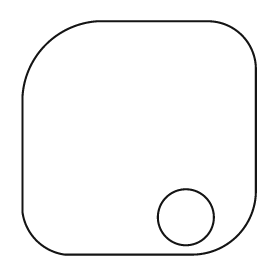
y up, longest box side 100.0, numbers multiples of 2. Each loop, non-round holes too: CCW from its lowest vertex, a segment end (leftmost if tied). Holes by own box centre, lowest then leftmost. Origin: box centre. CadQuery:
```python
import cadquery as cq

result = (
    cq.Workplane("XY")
    .moveTo(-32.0, -50.0)
    .lineTo(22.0, -50.0)
    .threePointArc((42.0, -42.0), (50.0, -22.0))
    .lineTo(50.0, 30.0)
    .threePointArc((44.0, 44.0), (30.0, 50.0))
    .lineTo(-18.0, 50.0)
    .threePointArc((-40.0, 40.0), (-50.0, 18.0))
    .lineTo(-50.0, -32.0)
    .threePointArc((-44.0, -44.0), (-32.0, -50.0))
    .close()
    .moveTo(20.0, -34.0)
    .circle(12.0)
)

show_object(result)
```